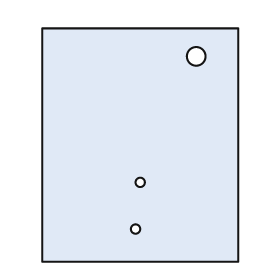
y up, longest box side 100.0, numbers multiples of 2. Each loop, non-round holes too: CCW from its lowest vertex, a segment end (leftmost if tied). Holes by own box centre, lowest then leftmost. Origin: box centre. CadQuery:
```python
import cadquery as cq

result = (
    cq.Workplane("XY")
    .moveTo(-42.0, -50.0)
    .lineTo(42.0, -50.0)
    .lineTo(42.0, 50.0)
    .lineTo(-42.0, 50.0)
    .close()
    .moveTo(-2.0, -36.0)
    .circle(2.0)
    .moveTo(0.0, -16.0)
    .circle(2.0)
    .moveTo(24.0, 38.0)
    .circle(4.0)
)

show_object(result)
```